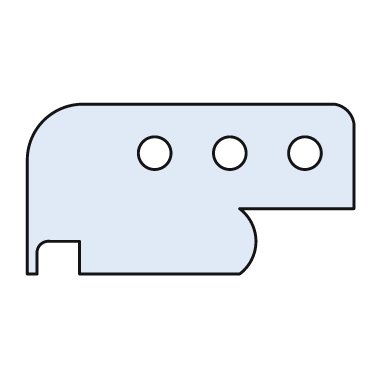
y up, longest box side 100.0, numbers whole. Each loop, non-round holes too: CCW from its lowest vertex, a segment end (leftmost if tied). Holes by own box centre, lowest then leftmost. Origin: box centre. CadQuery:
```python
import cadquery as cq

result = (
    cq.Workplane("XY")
    .moveTo(-50.0, -26.0)
    .lineTo(-47.0, -26.0)
    .lineTo(-47.0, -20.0)
    .threePointArc((-46.0, -17.0), (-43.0, -16.0))
    .lineTo(-34.0, -16.0)
    .lineTo(-34.0, -26.0)
    .lineTo(15.0, -26.0)
    .threePointArc((20.0, -16.0), (15.0, -6.0))
    .lineTo(50.0, -6.0)
    .lineTo(50.0, 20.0)
    .threePointArc((48.0, 24.0), (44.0, 26.0))
    .lineTo(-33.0, 26.0)
    .threePointArc((-45.0, 21.0), (-50.0, 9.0))
    .close()
    .moveTo(-11.0, 11.0)
    .circle(5.0)
    .moveTo(12.0, 11.0)
    .circle(5.0)
    .moveTo(35.0, 11.0)
    .circle(5.0)
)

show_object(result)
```